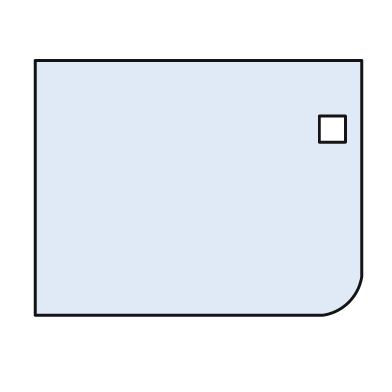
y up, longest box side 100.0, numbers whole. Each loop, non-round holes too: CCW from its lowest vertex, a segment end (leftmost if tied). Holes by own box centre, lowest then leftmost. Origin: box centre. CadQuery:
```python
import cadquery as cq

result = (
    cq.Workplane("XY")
    .moveTo(-50.0, -39.0)
    .lineTo(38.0, -39.0)
    .threePointArc((46.0, -35.0), (50.0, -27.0))
    .lineTo(50.0, 39.0)
    .lineTo(-50.0, 39.0)
    .close()
    .moveTo(37.0, 14.0)
    .lineTo(45.0, 14.0)
    .lineTo(45.0, 22.0)
    .lineTo(37.0, 22.0)
    .close()
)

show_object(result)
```